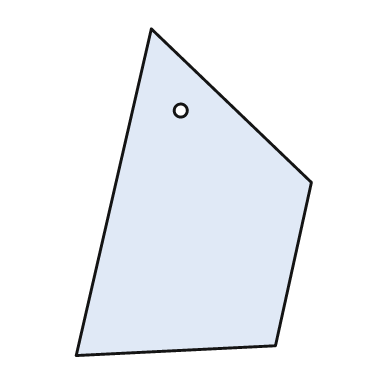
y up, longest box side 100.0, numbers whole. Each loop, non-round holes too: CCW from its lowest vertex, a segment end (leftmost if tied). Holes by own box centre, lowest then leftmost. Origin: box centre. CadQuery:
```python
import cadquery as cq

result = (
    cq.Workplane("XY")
    .moveTo(-36.0, -50.0)
    .lineTo(25.0, -47.0)
    .lineTo(36.0, 3.0)
    .lineTo(-13.0, 50.0)
    .close()
    .moveTo(-4.0, 25.0)
    .circle(2.0)
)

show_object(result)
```